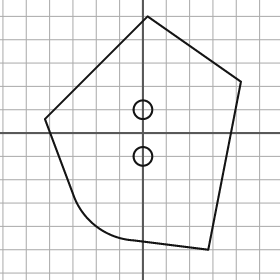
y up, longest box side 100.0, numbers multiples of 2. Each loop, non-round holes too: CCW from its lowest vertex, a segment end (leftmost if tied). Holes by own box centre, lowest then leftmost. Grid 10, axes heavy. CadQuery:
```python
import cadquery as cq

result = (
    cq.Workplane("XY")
    .moveTo(28.0, -50.0)
    .lineTo(42.0, 22.0)
    .lineTo(2.0, 50.0)
    .lineTo(-42.0, 6.0)
    .lineTo(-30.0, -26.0)
    .threePointArc((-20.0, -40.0), (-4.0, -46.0))
    .close()
    .moveTo(0.0, -10.0)
    .circle(4.0)
    .moveTo(0.0, 10.0)
    .circle(4.0)
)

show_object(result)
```